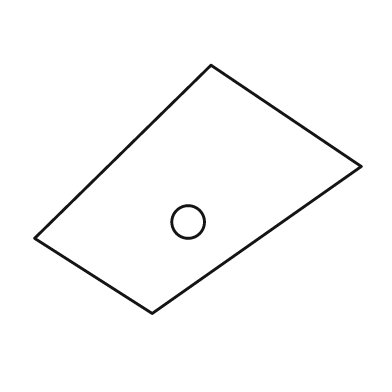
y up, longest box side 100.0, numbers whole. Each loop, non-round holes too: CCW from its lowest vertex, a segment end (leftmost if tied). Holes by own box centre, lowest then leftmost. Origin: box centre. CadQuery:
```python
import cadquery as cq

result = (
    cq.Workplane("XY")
    .moveTo(-14.0, -38.0)
    .lineTo(50.0, 7.0)
    .lineTo(4.0, 38.0)
    .lineTo(-50.0, -15.0)
    .close()
    .moveTo(-3.0, -10.0)
    .circle(5.0)
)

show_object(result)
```